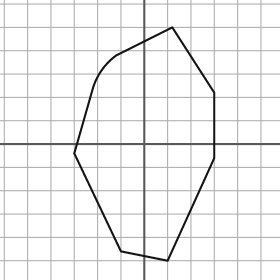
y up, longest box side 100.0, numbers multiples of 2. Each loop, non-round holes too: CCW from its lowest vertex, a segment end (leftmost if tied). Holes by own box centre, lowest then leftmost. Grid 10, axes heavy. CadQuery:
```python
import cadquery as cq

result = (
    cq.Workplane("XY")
    .moveTo(10.0, -50.0)
    .lineTo(30.0, -6.0)
    .lineTo(30.0, 22.0)
    .lineTo(12.0, 50.0)
    .lineTo(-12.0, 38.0)
    .threePointArc((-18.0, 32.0), (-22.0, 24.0))
    .lineTo(-30.0, -4.0)
    .lineTo(-10.0, -46.0)
    .close()
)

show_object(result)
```